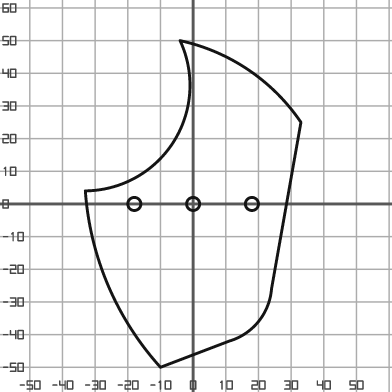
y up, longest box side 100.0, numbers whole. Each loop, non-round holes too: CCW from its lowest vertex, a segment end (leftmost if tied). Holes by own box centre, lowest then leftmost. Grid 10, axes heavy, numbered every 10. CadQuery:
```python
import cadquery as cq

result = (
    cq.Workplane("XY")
    .moveTo(-10.0, -50.0)
    .lineTo(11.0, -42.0)
    .threePointArc((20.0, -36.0), (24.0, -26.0))
    .lineTo(33.0, 25.0)
    .threePointArc((17.0, 41.0), (-4.0, 50.0))
    .threePointArc((-6.0, 19.0), (-33.0, 4.0))
    .threePointArc((-26.0, -25.0), (-10.0, -50.0))
    .close()
    .moveTo(-18.0, 0.0)
    .circle(2.0)
    .moveTo(0.0, 0.0)
    .circle(2.0)
    .moveTo(18.0, 0.0)
    .circle(2.0)
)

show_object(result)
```